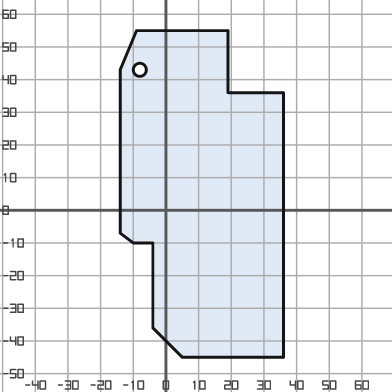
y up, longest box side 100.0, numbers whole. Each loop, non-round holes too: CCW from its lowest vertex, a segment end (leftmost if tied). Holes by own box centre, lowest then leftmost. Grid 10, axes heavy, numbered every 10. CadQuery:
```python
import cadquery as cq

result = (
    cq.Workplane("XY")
    .moveTo(5.0, -45.0)
    .lineTo(36.0, -45.0)
    .lineTo(36.0, 36.0)
    .lineTo(19.0, 36.0)
    .lineTo(19.0, 55.0)
    .lineTo(-9.0, 55.0)
    .lineTo(-14.0, 43.0)
    .lineTo(-14.0, -7.0)
    .lineTo(-10.0, -10.0)
    .lineTo(-4.0, -10.0)
    .lineTo(-4.0, -36.0)
    .close()
    .moveTo(-8.0, 43.0)
    .circle(2.0)
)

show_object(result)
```